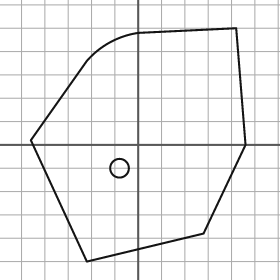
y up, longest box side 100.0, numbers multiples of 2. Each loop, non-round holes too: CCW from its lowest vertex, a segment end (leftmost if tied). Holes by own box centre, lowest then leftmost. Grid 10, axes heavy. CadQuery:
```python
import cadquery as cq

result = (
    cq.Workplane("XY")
    .moveTo(-22.0, -50.0)
    .lineTo(28.0, -38.0)
    .lineTo(46.0, 0.0)
    .lineTo(42.0, 50.0)
    .lineTo(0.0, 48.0)
    .threePointArc((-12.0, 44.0), (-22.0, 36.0))
    .lineTo(-46.0, 2.0)
    .close()
    .moveTo(-8.0, -10.0)
    .circle(4.0)
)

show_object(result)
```